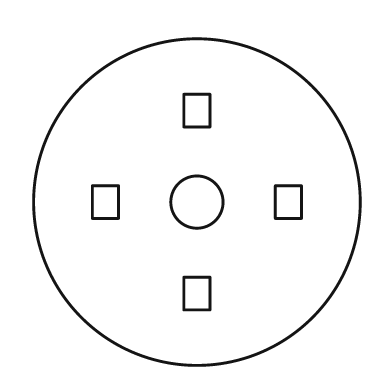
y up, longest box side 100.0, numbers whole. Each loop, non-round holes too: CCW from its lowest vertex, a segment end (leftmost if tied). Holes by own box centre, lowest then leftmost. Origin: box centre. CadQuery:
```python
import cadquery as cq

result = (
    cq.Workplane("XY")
    .moveTo(0.0, 0.0)
    .circle(50.0)
    .moveTo(-4.0, -33.0)
    .lineTo(4.0, -33.0)
    .lineTo(4.0, -23.0)
    .lineTo(-4.0, -23.0)
    .close()
    .moveTo(-32.0, -5.0)
    .lineTo(-24.0, -5.0)
    .lineTo(-24.0, 5.0)
    .lineTo(-32.0, 5.0)
    .close()
    .moveTo(0.0, 0.0)
    .circle(8.0)
    .moveTo(24.0, -5.0)
    .lineTo(32.0, -5.0)
    .lineTo(32.0, 5.0)
    .lineTo(24.0, 5.0)
    .close()
    .moveTo(-4.0, 23.0)
    .lineTo(4.0, 23.0)
    .lineTo(4.0, 33.0)
    .lineTo(-4.0, 33.0)
    .close()
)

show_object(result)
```